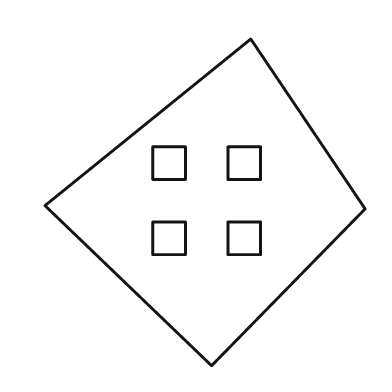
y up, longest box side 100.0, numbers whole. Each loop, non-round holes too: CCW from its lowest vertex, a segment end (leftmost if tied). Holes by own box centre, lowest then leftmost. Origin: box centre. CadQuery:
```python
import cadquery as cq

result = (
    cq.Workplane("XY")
    .moveTo(2.0, -50.0)
    .lineTo(49.0, -2.0)
    .lineTo(14.0, 50.0)
    .lineTo(-49.0, -1.0)
    .close()
    .moveTo(-16.0, -16.0)
    .lineTo(-6.0, -16.0)
    .lineTo(-6.0, -6.0)
    .lineTo(-16.0, -6.0)
    .close()
    .moveTo(7.0, -16.0)
    .lineTo(17.0, -16.0)
    .lineTo(17.0, -6.0)
    .lineTo(7.0, -6.0)
    .close()
    .moveTo(-16.0, 7.0)
    .lineTo(-6.0, 7.0)
    .lineTo(-6.0, 17.0)
    .lineTo(-16.0, 17.0)
    .close()
    .moveTo(7.0, 7.0)
    .lineTo(17.0, 7.0)
    .lineTo(17.0, 17.0)
    .lineTo(7.0, 17.0)
    .close()
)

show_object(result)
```